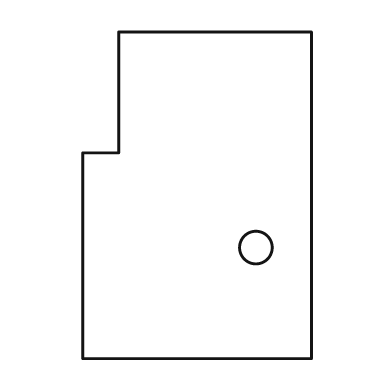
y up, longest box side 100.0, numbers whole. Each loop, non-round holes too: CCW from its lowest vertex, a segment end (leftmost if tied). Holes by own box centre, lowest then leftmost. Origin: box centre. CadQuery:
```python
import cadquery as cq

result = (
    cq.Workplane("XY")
    .moveTo(-35.0, -50.0)
    .lineTo(35.0, -50.0)
    .lineTo(35.0, 50.0)
    .lineTo(-24.0, 50.0)
    .lineTo(-24.0, 13.0)
    .lineTo(-35.0, 13.0)
    .close()
    .moveTo(18.0, -16.0)
    .circle(5.0)
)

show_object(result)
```